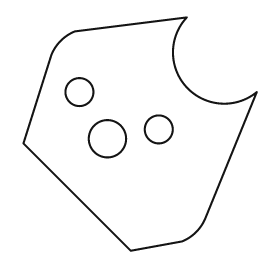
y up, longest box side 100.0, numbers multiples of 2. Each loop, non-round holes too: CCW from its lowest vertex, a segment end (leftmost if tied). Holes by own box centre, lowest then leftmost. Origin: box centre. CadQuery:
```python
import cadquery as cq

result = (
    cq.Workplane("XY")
    .moveTo(-4.0, -50.0)
    .lineTo(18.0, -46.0)
    .threePointArc((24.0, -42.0), (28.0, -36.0))
    .lineTo(50.0, 18.0)
    .threePointArc((20.0, 20.0), (20.0, 50.0))
    .lineTo(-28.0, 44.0)
    .threePointArc((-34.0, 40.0), (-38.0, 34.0))
    .lineTo(-50.0, -4.0)
    .close()
    .moveTo(-14.0, -2.0)
    .circle(8.0)
    .moveTo(8.0, 2.0)
    .circle(6.0)
    .moveTo(-26.0, 18.0)
    .circle(6.0)
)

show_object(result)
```